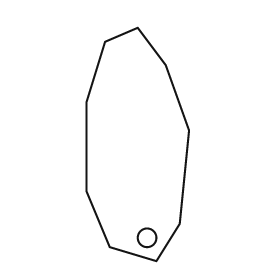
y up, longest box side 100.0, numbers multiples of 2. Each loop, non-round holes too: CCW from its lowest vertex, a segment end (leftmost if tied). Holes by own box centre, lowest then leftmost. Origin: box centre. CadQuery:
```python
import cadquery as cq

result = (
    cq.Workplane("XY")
    .moveTo(8.0, -50.0)
    .lineTo(18.0, -34.0)
    .lineTo(22.0, 6.0)
    .lineTo(12.0, 34.0)
    .lineTo(0.0, 50.0)
    .lineTo(-14.0, 44.0)
    .lineTo(-22.0, 18.0)
    .lineTo(-22.0, -20.0)
    .lineTo(-12.0, -44.0)
    .close()
    .moveTo(4.0, -40.0)
    .circle(4.0)
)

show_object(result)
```